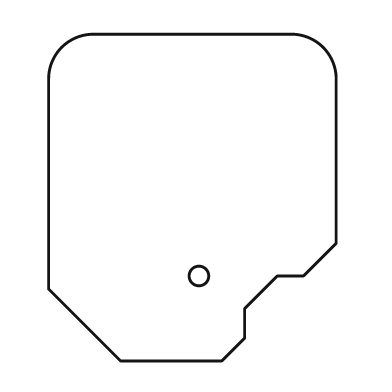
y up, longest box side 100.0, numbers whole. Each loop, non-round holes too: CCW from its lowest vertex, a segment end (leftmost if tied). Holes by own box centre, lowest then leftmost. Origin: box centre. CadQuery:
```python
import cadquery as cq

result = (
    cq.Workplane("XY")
    .moveTo(-22.0, -50.0)
    .lineTo(9.0, -50.0)
    .lineTo(16.0, -43.0)
    .lineTo(16.0, -34.0)
    .lineTo(26.0, -24.0)
    .lineTo(34.0, -24.0)
    .lineTo(44.0, -14.0)
    .lineTo(44.0, 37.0)
    .threePointArc((40.0, 46.0), (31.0, 50.0))
    .lineTo(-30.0, 50.0)
    .threePointArc((-40.0, 46.0), (-44.0, 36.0))
    .lineTo(-44.0, -28.0)
    .close()
    .moveTo(2.0, -24.0)
    .circle(3.0)
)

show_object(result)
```